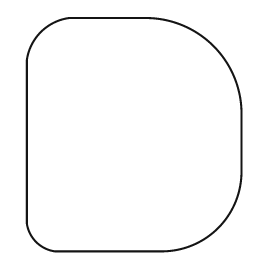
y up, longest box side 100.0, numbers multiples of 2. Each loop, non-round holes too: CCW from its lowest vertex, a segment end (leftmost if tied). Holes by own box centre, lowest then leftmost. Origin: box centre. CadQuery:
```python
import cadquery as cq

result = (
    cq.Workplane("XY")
    .moveTo(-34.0, -50.0)
    .lineTo(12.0, -50.0)
    .threePointArc((36.0, -40.0), (46.0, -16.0))
    .lineTo(46.0, 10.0)
    .threePointArc((34.0, 38.0), (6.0, 50.0))
    .lineTo(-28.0, 50.0)
    .threePointArc((-40.0, 44.0), (-46.0, 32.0))
    .lineTo(-46.0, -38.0)
    .threePointArc((-42.0, -46.0), (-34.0, -50.0))
    .close()
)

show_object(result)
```